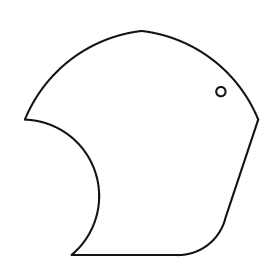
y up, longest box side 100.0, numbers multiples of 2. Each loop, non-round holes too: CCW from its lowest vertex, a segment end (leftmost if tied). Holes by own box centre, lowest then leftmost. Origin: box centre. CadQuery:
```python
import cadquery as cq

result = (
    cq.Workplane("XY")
    .moveTo(-30.0, -48.0)
    .lineTo(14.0, -48.0)
    .threePointArc((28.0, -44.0), (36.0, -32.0))
    .lineTo(50.0, 10.0)
    .threePointArc((30.0, 36.0), (0.0, 48.0))
    .threePointArc((-30.0, 36.0), (-50.0, 10.0))
    .threePointArc((-20.0, -12.0), (-30.0, -48.0))
    .close()
    .moveTo(34.0, 22.0)
    .circle(2.0)
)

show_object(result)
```